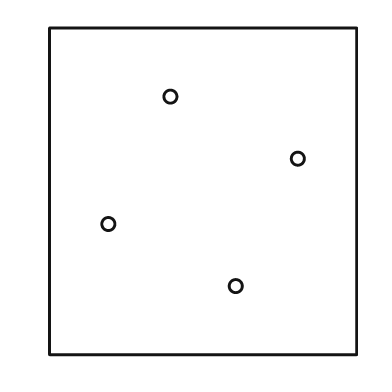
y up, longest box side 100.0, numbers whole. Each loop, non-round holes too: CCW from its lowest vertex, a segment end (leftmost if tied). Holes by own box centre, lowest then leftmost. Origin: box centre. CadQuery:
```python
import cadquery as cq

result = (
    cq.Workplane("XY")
    .moveTo(-47.0, -50.0)
    .lineTo(47.0, -50.0)
    .lineTo(47.0, 50.0)
    .lineTo(-47.0, 50.0)
    .close()
    .moveTo(10.0, -29.0)
    .circle(2.0)
    .moveTo(-29.0, -10.0)
    .circle(2.0)
    .moveTo(29.0, 10.0)
    .circle(2.0)
    .moveTo(-10.0, 29.0)
    .circle(2.0)
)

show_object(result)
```